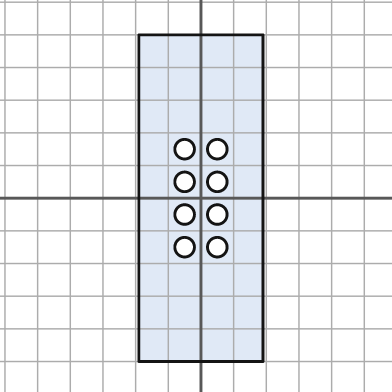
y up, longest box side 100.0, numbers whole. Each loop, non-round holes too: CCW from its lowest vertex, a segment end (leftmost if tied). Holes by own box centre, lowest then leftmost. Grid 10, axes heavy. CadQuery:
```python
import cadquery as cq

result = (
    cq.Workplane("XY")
    .moveTo(-19.0, -50.0)
    .lineTo(19.0, -50.0)
    .lineTo(19.0, 50.0)
    .lineTo(-19.0, 50.0)
    .close()
    .moveTo(-5.0, -15.0)
    .circle(3.0)
    .moveTo(5.0, -15.0)
    .circle(3.0)
    .moveTo(-5.0, -5.0)
    .circle(3.0)
    .moveTo(5.0, -5.0)
    .circle(3.0)
    .moveTo(-5.0, 5.0)
    .circle(3.0)
    .moveTo(5.0, 5.0)
    .circle(3.0)
    .moveTo(-5.0, 15.0)
    .circle(3.0)
    .moveTo(5.0, 15.0)
    .circle(3.0)
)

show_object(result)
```